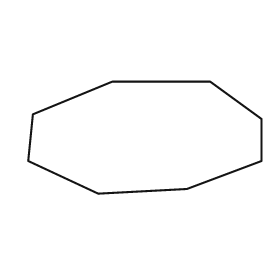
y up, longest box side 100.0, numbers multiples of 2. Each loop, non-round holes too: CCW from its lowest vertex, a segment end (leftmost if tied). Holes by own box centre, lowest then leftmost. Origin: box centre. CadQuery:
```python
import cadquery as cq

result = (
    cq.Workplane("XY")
    .moveTo(-20.0, -24.0)
    .lineTo(18.0, -22.0)
    .lineTo(50.0, -10.0)
    .lineTo(50.0, 8.0)
    .lineTo(28.0, 24.0)
    .lineTo(-14.0, 24.0)
    .lineTo(-48.0, 10.0)
    .lineTo(-50.0, -10.0)
    .close()
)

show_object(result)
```